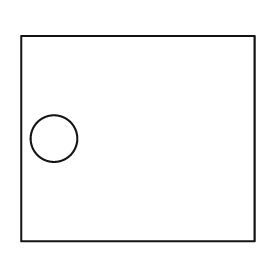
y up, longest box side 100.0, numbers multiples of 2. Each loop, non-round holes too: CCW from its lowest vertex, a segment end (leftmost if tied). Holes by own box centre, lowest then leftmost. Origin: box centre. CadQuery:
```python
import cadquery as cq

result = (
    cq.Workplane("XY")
    .moveTo(-50.0, -44.0)
    .lineTo(50.0, -44.0)
    .lineTo(50.0, 44.0)
    .lineTo(-50.0, 44.0)
    .close()
    .moveTo(-36.0, 0.0)
    .circle(10.0)
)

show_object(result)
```